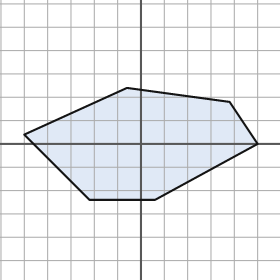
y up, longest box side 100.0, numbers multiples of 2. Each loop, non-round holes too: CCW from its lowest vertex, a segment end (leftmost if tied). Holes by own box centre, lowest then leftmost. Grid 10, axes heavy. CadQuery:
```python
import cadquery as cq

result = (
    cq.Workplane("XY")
    .moveTo(-22.0, -24.0)
    .lineTo(6.0, -24.0)
    .lineTo(50.0, 0.0)
    .lineTo(38.0, 18.0)
    .lineTo(-6.0, 24.0)
    .lineTo(-50.0, 4.0)
    .close()
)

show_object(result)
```